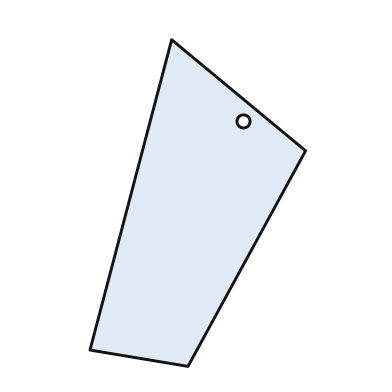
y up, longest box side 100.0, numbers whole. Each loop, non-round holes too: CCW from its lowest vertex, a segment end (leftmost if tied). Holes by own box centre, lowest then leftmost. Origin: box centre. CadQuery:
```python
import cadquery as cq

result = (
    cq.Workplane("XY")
    .moveTo(-3.0, -50.0)
    .lineTo(33.0, 16.0)
    .lineTo(-8.0, 50.0)
    .lineTo(-33.0, -45.0)
    .close()
    .moveTo(14.0, 25.0)
    .circle(2.0)
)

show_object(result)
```